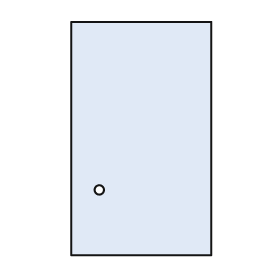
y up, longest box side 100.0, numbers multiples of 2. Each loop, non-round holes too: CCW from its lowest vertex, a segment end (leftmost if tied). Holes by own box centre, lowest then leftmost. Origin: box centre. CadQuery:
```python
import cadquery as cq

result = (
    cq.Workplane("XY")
    .moveTo(-30.0, -50.0)
    .lineTo(30.0, -50.0)
    .lineTo(30.0, 50.0)
    .lineTo(-30.0, 50.0)
    .close()
    .moveTo(-18.0, -22.0)
    .circle(2.0)
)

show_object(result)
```